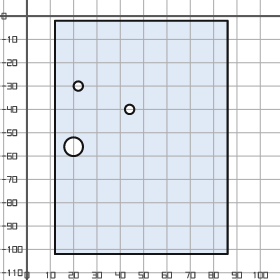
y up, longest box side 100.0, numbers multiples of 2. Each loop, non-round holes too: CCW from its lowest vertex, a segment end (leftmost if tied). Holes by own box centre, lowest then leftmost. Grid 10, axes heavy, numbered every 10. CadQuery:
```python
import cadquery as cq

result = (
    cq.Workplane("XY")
    .moveTo(12.0, -102.0)
    .lineTo(86.0, -102.0)
    .lineTo(86.0, -2.0)
    .lineTo(12.0, -2.0)
    .close()
    .moveTo(20.0, -56.0)
    .circle(4.0)
    .moveTo(44.0, -40.0)
    .circle(2.0)
    .moveTo(22.0, -30.0)
    .circle(2.0)
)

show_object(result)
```